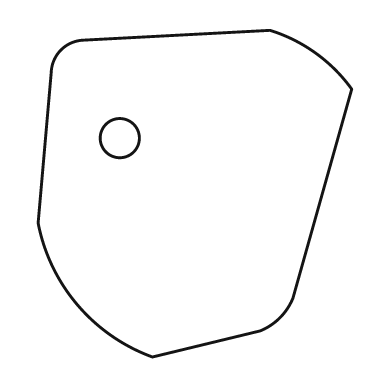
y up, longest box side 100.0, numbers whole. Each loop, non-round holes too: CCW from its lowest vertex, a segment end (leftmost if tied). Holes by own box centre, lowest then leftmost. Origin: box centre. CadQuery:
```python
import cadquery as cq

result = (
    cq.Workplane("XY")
    .moveTo(-13.0, -50.0)
    .lineTo(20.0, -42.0)
    .threePointArc((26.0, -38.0), (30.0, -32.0))
    .lineTo(48.0, 32.0)
    .threePointArc((37.0, 43.0), (23.0, 50.0))
    .lineTo(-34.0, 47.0)
    .threePointArc((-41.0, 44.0), (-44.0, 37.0))
    .lineTo(-48.0, -9.0)
    .threePointArc((-36.0, -34.0), (-13.0, -50.0))
    .close()
    .moveTo(-23.0, 17.0)
    .circle(6.0)
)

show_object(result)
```